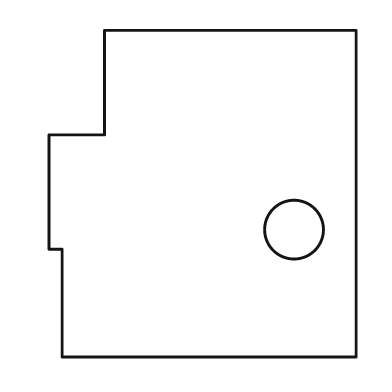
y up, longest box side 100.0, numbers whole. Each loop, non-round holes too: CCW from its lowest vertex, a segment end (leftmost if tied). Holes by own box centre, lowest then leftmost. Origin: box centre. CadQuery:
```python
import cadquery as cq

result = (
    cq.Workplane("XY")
    .moveTo(-43.0, -50.0)
    .lineTo(47.0, -50.0)
    .lineTo(47.0, 50.0)
    .lineTo(-30.0, 50.0)
    .lineTo(-30.0, 18.0)
    .lineTo(-47.0, 18.0)
    .lineTo(-47.0, -17.0)
    .lineTo(-43.0, -17.0)
    .close()
    .moveTo(28.0, -11.0)
    .circle(9.0)
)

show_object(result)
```